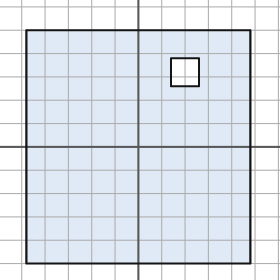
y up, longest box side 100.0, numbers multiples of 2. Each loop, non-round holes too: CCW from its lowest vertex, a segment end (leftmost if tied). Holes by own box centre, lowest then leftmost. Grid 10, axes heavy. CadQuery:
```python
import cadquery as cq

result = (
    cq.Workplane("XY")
    .moveTo(-48.0, -50.0)
    .lineTo(48.0, -50.0)
    .lineTo(48.0, 50.0)
    .lineTo(-48.0, 50.0)
    .close()
    .moveTo(14.0, 26.0)
    .lineTo(26.0, 26.0)
    .lineTo(26.0, 38.0)
    .lineTo(14.0, 38.0)
    .close()
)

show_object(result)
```